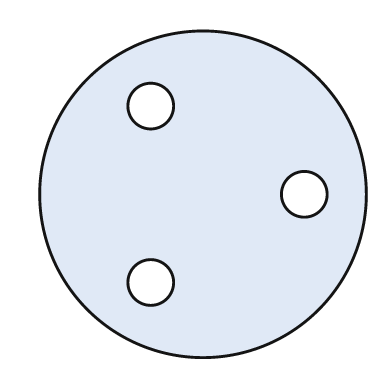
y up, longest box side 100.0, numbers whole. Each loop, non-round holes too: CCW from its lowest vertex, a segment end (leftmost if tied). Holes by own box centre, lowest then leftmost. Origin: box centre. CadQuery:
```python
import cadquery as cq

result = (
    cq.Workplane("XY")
    .moveTo(0.0, 0.0)
    .circle(50.0)
    .moveTo(-16.0, -27.0)
    .circle(7.0)
    .moveTo(31.0, 0.0)
    .circle(7.0)
    .moveTo(-16.0, 27.0)
    .circle(7.0)
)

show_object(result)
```